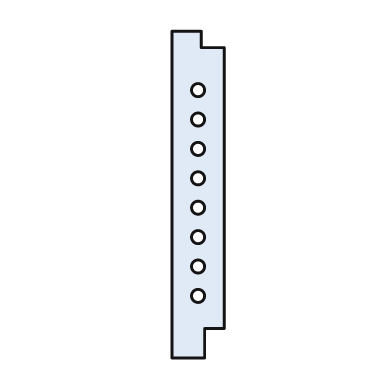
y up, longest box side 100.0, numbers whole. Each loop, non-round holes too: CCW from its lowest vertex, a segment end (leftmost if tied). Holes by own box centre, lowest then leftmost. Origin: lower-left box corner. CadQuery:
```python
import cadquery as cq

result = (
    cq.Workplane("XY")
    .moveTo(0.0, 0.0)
    .lineTo(10.0, 0.0)
    .lineTo(10.0, 9.0)
    .lineTo(16.0, 9.0)
    .lineTo(16.0, 95.0)
    .lineTo(9.0, 95.0)
    .lineTo(9.0, 100.0)
    .lineTo(0.0, 100.0)
    .close()
    .moveTo(8.0, 19.0)
    .circle(2.0)
    .moveTo(8.0, 28.0)
    .circle(2.0)
    .moveTo(8.0, 37.0)
    .circle(2.0)
    .moveTo(8.0, 46.0)
    .circle(2.0)
    .moveTo(8.0, 55.0)
    .circle(2.0)
    .moveTo(8.0, 64.0)
    .circle(2.0)
    .moveTo(8.0, 73.0)
    .circle(2.0)
    .moveTo(8.0, 82.0)
    .circle(2.0)
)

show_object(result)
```